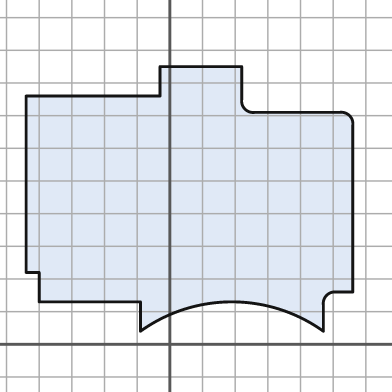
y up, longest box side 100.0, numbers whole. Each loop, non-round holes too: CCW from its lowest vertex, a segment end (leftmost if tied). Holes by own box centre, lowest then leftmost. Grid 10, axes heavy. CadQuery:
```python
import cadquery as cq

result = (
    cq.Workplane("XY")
    .moveTo(-9.0, 4.0)
    .threePointArc((19.0, 13.0), (47.0, 4.0))
    .lineTo(47.0, 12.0)
    .threePointArc((48.0, 15.0), (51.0, 16.0))
    .lineTo(56.0, 16.0)
    .lineTo(56.0, 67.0)
    .threePointArc((55.0, 70.0), (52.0, 71.0))
    .lineTo(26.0, 71.0)
    .threePointArc((23.0, 72.0), (22.0, 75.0))
    .lineTo(22.0, 85.0)
    .lineTo(-3.0, 85.0)
    .lineTo(-3.0, 76.0)
    .lineTo(-44.0, 76.0)
    .lineTo(-44.0, 22.0)
    .lineTo(-40.0, 22.0)
    .lineTo(-40.0, 13.0)
    .lineTo(-9.0, 13.0)
    .close()
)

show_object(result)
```